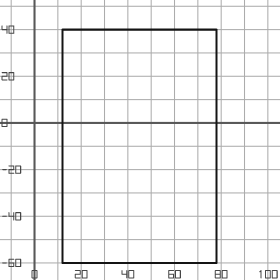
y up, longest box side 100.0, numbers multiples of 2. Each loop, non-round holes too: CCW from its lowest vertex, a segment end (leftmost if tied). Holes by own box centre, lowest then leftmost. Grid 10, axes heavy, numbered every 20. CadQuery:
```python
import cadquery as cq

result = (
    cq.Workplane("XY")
    .moveTo(12.0, -60.0)
    .lineTo(78.0, -60.0)
    .lineTo(78.0, 40.0)
    .lineTo(12.0, 40.0)
    .close()
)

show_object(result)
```